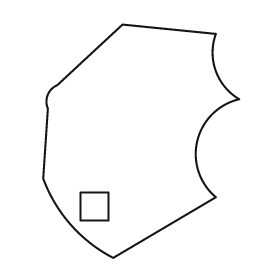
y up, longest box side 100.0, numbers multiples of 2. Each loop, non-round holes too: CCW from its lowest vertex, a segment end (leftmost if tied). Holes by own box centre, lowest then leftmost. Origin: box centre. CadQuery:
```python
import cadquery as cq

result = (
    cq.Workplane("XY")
    .moveTo(-12.0, -50.0)
    .lineTo(32.0, -24.0)
    .threePointArc((24.0, 0.0), (42.0, 18.0))
    .threePointArc((32.0, 30.0), (32.0, 46.0))
    .lineTo(-8.0, 50.0)
    .lineTo(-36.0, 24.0)
    .threePointArc((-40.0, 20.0), (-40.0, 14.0))
    .lineTo(-42.0, -16.0)
    .threePointArc((-30.0, -36.0), (-12.0, -50.0))
    .close()
    .moveTo(-26.0, -34.0)
    .lineTo(-14.0, -34.0)
    .lineTo(-14.0, -22.0)
    .lineTo(-26.0, -22.0)
    .close()
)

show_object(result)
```